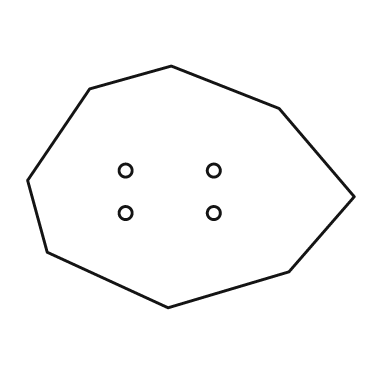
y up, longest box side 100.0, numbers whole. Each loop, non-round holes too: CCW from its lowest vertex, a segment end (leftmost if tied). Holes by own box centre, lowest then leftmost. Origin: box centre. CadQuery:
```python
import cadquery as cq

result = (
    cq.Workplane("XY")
    .moveTo(-7.0, -37.0)
    .lineTo(30.0, -26.0)
    .lineTo(50.0, -3.0)
    .lineTo(27.0, 24.0)
    .lineTo(-6.0, 37.0)
    .lineTo(-31.0, 30.0)
    .lineTo(-50.0, 2.0)
    .lineTo(-44.0, -20.0)
    .close()
    .moveTo(-20.0, -8.0)
    .circle(2.0)
    .moveTo(7.0, -8.0)
    .circle(2.0)
    .moveTo(-20.0, 5.0)
    .circle(2.0)
    .moveTo(7.0, 5.0)
    .circle(2.0)
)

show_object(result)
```